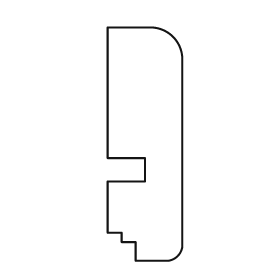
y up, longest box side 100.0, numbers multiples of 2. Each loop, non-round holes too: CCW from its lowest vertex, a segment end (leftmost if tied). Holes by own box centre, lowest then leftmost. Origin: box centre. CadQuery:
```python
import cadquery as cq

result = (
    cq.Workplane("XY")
    .moveTo(-4.0, -50.0)
    .lineTo(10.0, -50.0)
    .threePointArc((14.0, -48.0), (16.0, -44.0))
    .lineTo(16.0, 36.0)
    .threePointArc((12.0, 46.0), (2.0, 50.0))
    .lineTo(-16.0, 50.0)
    .lineTo(-16.0, -6.0)
    .lineTo(0.0, -6.0)
    .lineTo(0.0, -16.0)
    .lineTo(-16.0, -16.0)
    .lineTo(-16.0, -38.0)
    .lineTo(-10.0, -38.0)
    .lineTo(-10.0, -42.0)
    .lineTo(-4.0, -42.0)
    .close()
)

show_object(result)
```